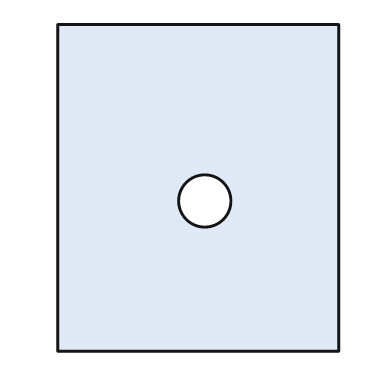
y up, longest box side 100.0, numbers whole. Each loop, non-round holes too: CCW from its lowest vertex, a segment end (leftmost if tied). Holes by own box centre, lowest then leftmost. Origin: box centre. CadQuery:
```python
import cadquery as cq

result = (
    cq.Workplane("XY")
    .moveTo(-43.0, -50.0)
    .lineTo(43.0, -50.0)
    .lineTo(43.0, 50.0)
    .lineTo(-43.0, 50.0)
    .close()
    .moveTo(2.0, -4.0)
    .circle(8.0)
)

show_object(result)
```